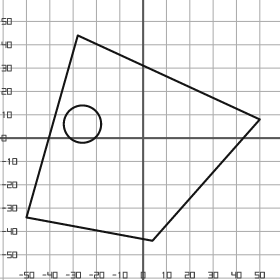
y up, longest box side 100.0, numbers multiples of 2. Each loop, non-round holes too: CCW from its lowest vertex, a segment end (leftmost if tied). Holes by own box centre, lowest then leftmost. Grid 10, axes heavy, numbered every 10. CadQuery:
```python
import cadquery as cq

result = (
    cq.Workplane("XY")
    .moveTo(4.0, -44.0)
    .lineTo(50.0, 8.0)
    .lineTo(-28.0, 44.0)
    .lineTo(-50.0, -34.0)
    .close()
    .moveTo(-26.0, 6.0)
    .circle(8.0)
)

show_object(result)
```